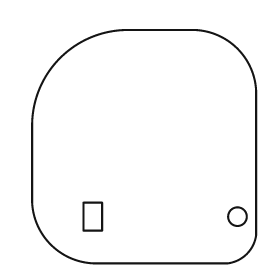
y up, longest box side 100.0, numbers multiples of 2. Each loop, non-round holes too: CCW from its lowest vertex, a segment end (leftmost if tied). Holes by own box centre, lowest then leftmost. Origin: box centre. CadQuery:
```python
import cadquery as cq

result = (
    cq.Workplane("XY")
    .moveTo(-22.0, -50.0)
    .lineTo(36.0, -50.0)
    .threePointArc((44.0, -46.0), (48.0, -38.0))
    .lineTo(48.0, 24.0)
    .threePointArc((40.0, 42.0), (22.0, 50.0))
    .lineTo(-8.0, 50.0)
    .threePointArc((-36.0, 38.0), (-48.0, 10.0))
    .lineTo(-48.0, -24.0)
    .threePointArc((-40.0, -42.0), (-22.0, -50.0))
    .close()
    .moveTo(-26.0, -36.0)
    .lineTo(-18.0, -36.0)
    .lineTo(-18.0, -24.0)
    .lineTo(-26.0, -24.0)
    .close()
    .moveTo(40.0, -30.0)
    .circle(4.0)
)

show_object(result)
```